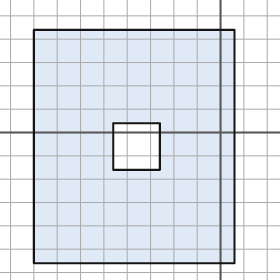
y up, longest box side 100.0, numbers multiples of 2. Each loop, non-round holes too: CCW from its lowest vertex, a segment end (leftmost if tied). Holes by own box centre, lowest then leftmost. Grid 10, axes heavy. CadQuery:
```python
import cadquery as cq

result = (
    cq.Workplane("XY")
    .moveTo(-80.0, -56.0)
    .lineTo(6.0, -56.0)
    .lineTo(6.0, 44.0)
    .lineTo(-80.0, 44.0)
    .close()
    .moveTo(-46.0, -16.0)
    .lineTo(-26.0, -16.0)
    .lineTo(-26.0, 4.0)
    .lineTo(-46.0, 4.0)
    .close()
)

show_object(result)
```